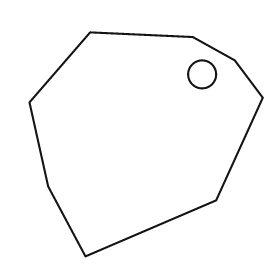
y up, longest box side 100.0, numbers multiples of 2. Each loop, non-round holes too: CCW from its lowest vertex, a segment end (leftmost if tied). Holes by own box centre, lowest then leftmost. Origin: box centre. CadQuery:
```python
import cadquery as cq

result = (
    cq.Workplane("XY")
    .moveTo(-26.0, -48.0)
    .lineTo(30.0, -24.0)
    .lineTo(50.0, 20.0)
    .lineTo(38.0, 36.0)
    .lineTo(20.0, 46.0)
    .lineTo(-24.0, 48.0)
    .lineTo(-50.0, 18.0)
    .lineTo(-42.0, -18.0)
    .close()
    .moveTo(24.0, 30.0)
    .circle(6.0)
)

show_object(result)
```